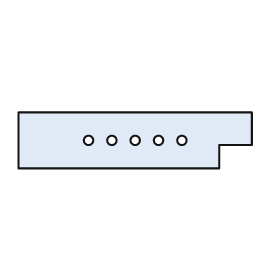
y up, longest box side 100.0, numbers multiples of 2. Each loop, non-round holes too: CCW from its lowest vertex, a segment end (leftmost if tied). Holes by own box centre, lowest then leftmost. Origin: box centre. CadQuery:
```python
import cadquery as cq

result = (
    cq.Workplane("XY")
    .moveTo(-50.0, -12.0)
    .lineTo(36.0, -12.0)
    .lineTo(36.0, -2.0)
    .lineTo(50.0, -2.0)
    .lineTo(50.0, 12.0)
    .lineTo(-50.0, 12.0)
    .close()
    .moveTo(-20.0, 0.0)
    .circle(2.0)
    .moveTo(-10.0, 0.0)
    .circle(2.0)
    .moveTo(0.0, 0.0)
    .circle(2.0)
    .moveTo(10.0, 0.0)
    .circle(2.0)
    .moveTo(20.0, 0.0)
    .circle(2.0)
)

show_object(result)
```